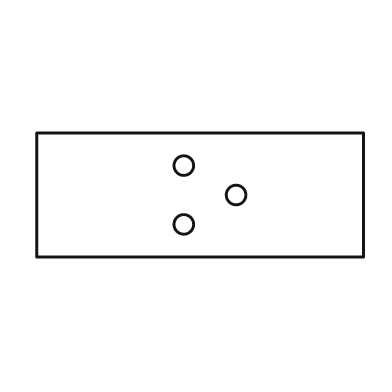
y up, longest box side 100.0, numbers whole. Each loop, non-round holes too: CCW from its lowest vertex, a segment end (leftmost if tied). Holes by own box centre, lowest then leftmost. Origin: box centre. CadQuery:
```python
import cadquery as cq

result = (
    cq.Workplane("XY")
    .moveTo(-50.0, -19.0)
    .lineTo(50.0, -19.0)
    .lineTo(50.0, 19.0)
    .lineTo(-50.0, 19.0)
    .close()
    .moveTo(-5.0, -9.0)
    .circle(3.0)
    .moveTo(11.0, 0.0)
    .circle(3.0)
    .moveTo(-5.0, 9.0)
    .circle(3.0)
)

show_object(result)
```